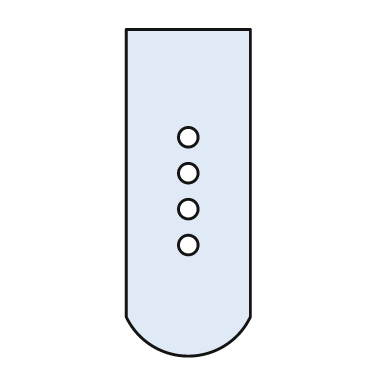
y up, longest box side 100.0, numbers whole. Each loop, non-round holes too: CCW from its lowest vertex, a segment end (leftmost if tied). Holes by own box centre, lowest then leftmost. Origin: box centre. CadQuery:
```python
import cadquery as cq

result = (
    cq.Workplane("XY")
    .moveTo(-19.0, -38.0)
    .threePointArc((0.0, -50.0), (19.0, -38.0))
    .lineTo(19.0, 50.0)
    .lineTo(-19.0, 50.0)
    .close()
    .moveTo(0.0, -16.0)
    .circle(3.0)
    .moveTo(0.0, -5.0)
    .circle(3.0)
    .moveTo(0.0, 6.0)
    .circle(3.0)
    .moveTo(0.0, 17.0)
    .circle(3.0)
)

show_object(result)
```